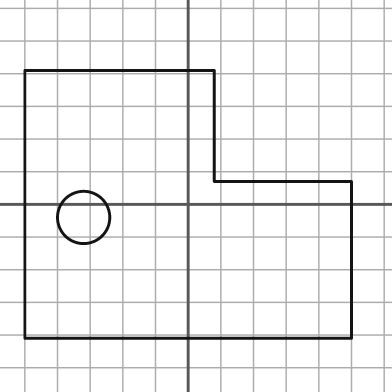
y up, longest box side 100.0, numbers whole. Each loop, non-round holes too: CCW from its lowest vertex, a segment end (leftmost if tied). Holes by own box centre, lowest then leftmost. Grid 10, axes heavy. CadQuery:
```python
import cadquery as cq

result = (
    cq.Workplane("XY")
    .moveTo(-50.0, -41.0)
    .lineTo(50.0, -41.0)
    .lineTo(50.0, 7.0)
    .lineTo(8.0, 7.0)
    .lineTo(8.0, 41.0)
    .lineTo(-50.0, 41.0)
    .close()
    .moveTo(-32.0, -4.0)
    .circle(8.0)
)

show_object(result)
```